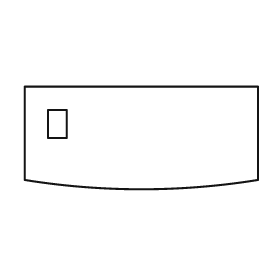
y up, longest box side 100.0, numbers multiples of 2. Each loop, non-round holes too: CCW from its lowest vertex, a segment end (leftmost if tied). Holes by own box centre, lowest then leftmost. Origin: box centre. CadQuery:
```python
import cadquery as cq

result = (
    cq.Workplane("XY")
    .moveTo(-50.0, -18.0)
    .threePointArc((0.0, -22.0), (50.0, -18.0))
    .lineTo(50.0, 22.0)
    .lineTo(-50.0, 22.0)
    .close()
    .moveTo(-40.0, 0.0)
    .lineTo(-32.0, 0.0)
    .lineTo(-32.0, 12.0)
    .lineTo(-40.0, 12.0)
    .close()
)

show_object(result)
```